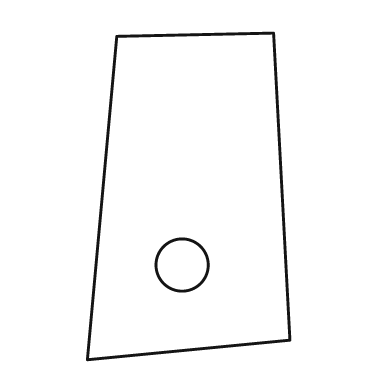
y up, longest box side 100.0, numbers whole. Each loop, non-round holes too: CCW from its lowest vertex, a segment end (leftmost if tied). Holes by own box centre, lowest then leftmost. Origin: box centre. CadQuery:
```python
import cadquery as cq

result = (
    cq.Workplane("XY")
    .moveTo(-31.0, -50.0)
    .lineTo(31.0, -44.0)
    .lineTo(26.0, 50.0)
    .lineTo(-22.0, 49.0)
    .close()
    .moveTo(-2.0, -21.0)
    .circle(8.0)
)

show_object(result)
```